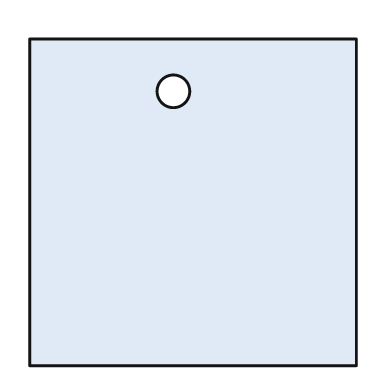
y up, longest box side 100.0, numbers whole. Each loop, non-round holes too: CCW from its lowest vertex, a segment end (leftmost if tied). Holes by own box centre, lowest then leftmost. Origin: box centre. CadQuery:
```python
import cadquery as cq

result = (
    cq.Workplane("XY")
    .moveTo(-50.0, -50.0)
    .lineTo(50.0, -50.0)
    .lineTo(50.0, 50.0)
    .lineTo(-50.0, 50.0)
    .close()
    .moveTo(-6.0, 34.0)
    .circle(5.0)
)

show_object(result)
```